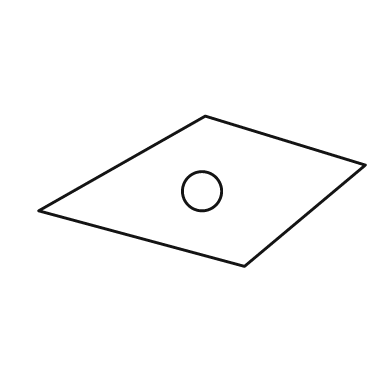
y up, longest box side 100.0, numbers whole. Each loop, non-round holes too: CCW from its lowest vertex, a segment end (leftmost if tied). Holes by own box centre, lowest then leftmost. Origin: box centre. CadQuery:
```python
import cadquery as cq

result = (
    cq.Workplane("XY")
    .moveTo(13.0, -23.0)
    .lineTo(50.0, 8.0)
    .lineTo(1.0, 23.0)
    .lineTo(-50.0, -6.0)
    .close()
    .moveTo(0.0, 0.0)
    .circle(6.0)
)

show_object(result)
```